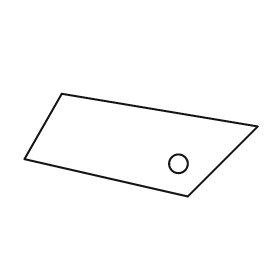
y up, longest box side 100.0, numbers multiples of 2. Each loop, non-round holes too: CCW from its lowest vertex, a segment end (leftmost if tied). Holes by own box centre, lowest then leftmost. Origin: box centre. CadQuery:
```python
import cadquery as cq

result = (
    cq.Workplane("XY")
    .moveTo(20.0, -22.0)
    .lineTo(50.0, 8.0)
    .lineTo(-34.0, 22.0)
    .lineTo(-50.0, -6.0)
    .close()
    .moveTo(16.0, -8.0)
    .circle(4.0)
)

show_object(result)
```